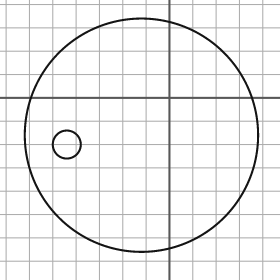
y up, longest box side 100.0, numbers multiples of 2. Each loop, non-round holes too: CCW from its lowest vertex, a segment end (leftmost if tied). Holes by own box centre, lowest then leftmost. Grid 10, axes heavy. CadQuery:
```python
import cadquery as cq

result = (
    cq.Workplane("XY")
    .moveTo(-12.0, -16.0)
    .circle(50.0)
    .moveTo(-44.0, -20.0)
    .circle(6.0)
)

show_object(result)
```